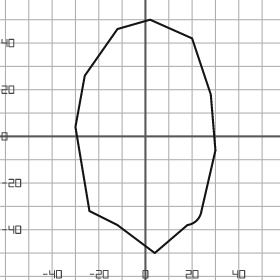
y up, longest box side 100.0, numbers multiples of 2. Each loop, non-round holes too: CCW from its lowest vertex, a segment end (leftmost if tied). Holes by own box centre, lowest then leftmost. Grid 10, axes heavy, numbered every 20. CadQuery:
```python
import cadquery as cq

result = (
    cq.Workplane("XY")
    .moveTo(4.0, -50.0)
    .lineTo(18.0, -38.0)
    .threePointArc((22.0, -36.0), (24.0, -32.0))
    .lineTo(30.0, -6.0)
    .lineTo(28.0, 18.0)
    .lineTo(20.0, 42.0)
    .lineTo(2.0, 50.0)
    .lineTo(-12.0, 46.0)
    .lineTo(-26.0, 26.0)
    .lineTo(-30.0, 4.0)
    .lineTo(-24.0, -32.0)
    .lineTo(-12.0, -38.0)
    .close()
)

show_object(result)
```